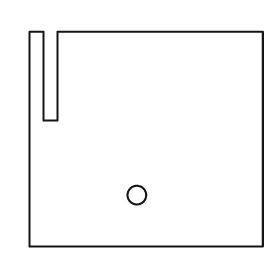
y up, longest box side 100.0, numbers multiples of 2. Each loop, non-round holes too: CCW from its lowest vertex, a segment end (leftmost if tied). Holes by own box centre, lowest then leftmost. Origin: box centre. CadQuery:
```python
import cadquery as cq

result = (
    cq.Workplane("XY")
    .moveTo(-50.0, -46.0)
    .lineTo(50.0, -46.0)
    .lineTo(50.0, 46.0)
    .lineTo(-38.0, 46.0)
    .lineTo(-38.0, 8.0)
    .lineTo(-44.0, 8.0)
    .lineTo(-44.0, 46.0)
    .lineTo(-50.0, 46.0)
    .close()
    .moveTo(-4.0, -24.0)
    .circle(4.0)
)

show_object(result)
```